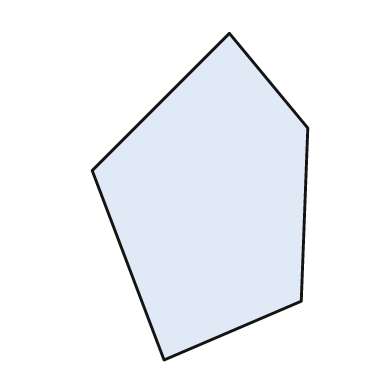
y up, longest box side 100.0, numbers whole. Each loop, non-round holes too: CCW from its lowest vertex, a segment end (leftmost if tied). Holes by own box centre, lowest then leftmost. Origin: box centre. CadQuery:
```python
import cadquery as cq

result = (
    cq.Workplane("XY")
    .moveTo(-11.0, -50.0)
    .lineTo(31.0, -32.0)
    .lineTo(33.0, 21.0)
    .lineTo(9.0, 50.0)
    .lineTo(-33.0, 8.0)
    .close()
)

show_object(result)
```